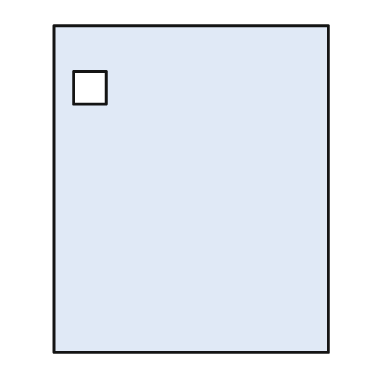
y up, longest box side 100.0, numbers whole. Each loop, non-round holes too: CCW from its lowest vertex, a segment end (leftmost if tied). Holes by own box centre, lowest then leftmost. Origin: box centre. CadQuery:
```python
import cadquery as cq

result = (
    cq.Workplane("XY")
    .moveTo(-42.0, -50.0)
    .lineTo(42.0, -50.0)
    .lineTo(42.0, 50.0)
    .lineTo(-42.0, 50.0)
    .close()
    .moveTo(-36.0, 26.0)
    .lineTo(-26.0, 26.0)
    .lineTo(-26.0, 36.0)
    .lineTo(-36.0, 36.0)
    .close()
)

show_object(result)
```